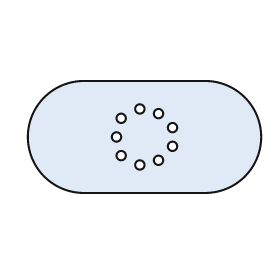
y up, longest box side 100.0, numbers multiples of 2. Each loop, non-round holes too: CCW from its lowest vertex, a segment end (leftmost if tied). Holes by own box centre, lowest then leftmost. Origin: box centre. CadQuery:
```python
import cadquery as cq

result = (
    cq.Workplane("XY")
    .moveTo(-26.0, -24.0)
    .lineTo(26.0, -24.0)
    .threePointArc((50.0, 0.0), (26.0, 24.0))
    .lineTo(-26.0, 24.0)
    .threePointArc((-50.0, 0.0), (-26.0, -24.0))
    .close()
    .moveTo(-2.0, -12.0)
    .circle(2.0)
    .moveTo(6.0, -10.0)
    .circle(2.0)
    .moveTo(-10.0, -8.0)
    .circle(2.0)
    .moveTo(12.0, -4.0)
    .circle(2.0)
    .moveTo(-12.0, 0.0)
    .circle(2.0)
    .moveTo(12.0, 4.0)
    .circle(2.0)
    .moveTo(-10.0, 8.0)
    .circle(2.0)
    .moveTo(6.0, 10.0)
    .circle(2.0)
    .moveTo(-2.0, 12.0)
    .circle(2.0)
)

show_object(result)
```